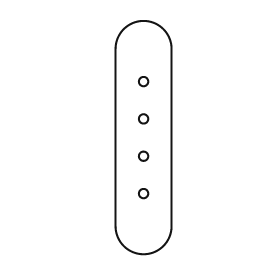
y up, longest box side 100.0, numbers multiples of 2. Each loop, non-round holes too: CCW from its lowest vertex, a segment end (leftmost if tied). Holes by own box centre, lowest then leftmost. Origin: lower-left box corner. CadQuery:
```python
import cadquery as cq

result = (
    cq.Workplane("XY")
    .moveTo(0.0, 12.0)
    .threePointArc((12.0, 0.0), (24.0, 12.0))
    .lineTo(24.0, 88.0)
    .threePointArc((12.0, 100.0), (0.0, 88.0))
    .close()
    .moveTo(12.0, 26.0)
    .circle(2.0)
    .moveTo(12.0, 42.0)
    .circle(2.0)
    .moveTo(12.0, 58.0)
    .circle(2.0)
    .moveTo(12.0, 74.0)
    .circle(2.0)
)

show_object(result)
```